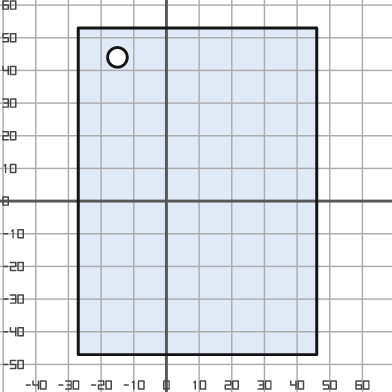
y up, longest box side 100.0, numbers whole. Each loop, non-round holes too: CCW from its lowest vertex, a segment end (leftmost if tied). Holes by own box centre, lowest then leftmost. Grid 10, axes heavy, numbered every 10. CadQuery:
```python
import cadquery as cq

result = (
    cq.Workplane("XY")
    .moveTo(-27.0, -47.0)
    .lineTo(46.0, -47.0)
    .lineTo(46.0, 53.0)
    .lineTo(-27.0, 53.0)
    .close()
    .moveTo(-15.0, 44.0)
    .circle(3.0)
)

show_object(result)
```